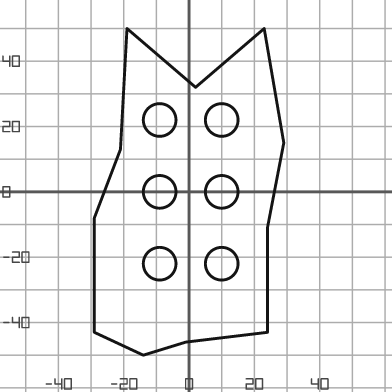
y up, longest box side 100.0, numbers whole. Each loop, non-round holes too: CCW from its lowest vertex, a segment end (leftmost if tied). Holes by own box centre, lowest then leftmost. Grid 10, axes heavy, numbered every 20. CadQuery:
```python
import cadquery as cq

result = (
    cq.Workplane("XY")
    .moveTo(-14.0, -50.0)
    .lineTo(-1.0, -46.0)
    .lineTo(24.0, -43.0)
    .lineTo(24.0, -11.0)
    .lineTo(29.0, 15.0)
    .lineTo(23.0, 50.0)
    .lineTo(2.0, 32.0)
    .lineTo(-19.0, 50.0)
    .lineTo(-21.0, 13.0)
    .lineTo(-29.0, -8.0)
    .lineTo(-29.0, -43.0)
    .close()
    .moveTo(-9.0, -22.0)
    .circle(5.0)
    .moveTo(10.0, -22.0)
    .circle(5.0)
    .moveTo(-9.0, 0.0)
    .circle(5.0)
    .moveTo(10.0, 0.0)
    .circle(5.0)
    .moveTo(-9.0, 22.0)
    .circle(5.0)
    .moveTo(10.0, 22.0)
    .circle(5.0)
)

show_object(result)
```